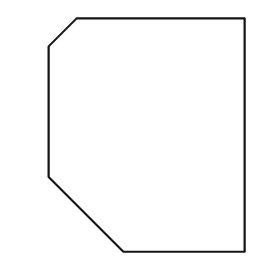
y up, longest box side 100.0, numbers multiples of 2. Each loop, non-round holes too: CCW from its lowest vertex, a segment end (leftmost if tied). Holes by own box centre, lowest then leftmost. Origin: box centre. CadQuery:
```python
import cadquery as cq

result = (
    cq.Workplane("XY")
    .moveTo(-10.0, -50.0)
    .lineTo(42.0, -50.0)
    .lineTo(42.0, 50.0)
    .lineTo(-30.0, 50.0)
    .lineTo(-42.0, 38.0)
    .lineTo(-42.0, -18.0)
    .close()
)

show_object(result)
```